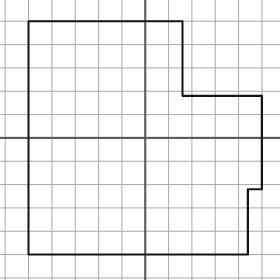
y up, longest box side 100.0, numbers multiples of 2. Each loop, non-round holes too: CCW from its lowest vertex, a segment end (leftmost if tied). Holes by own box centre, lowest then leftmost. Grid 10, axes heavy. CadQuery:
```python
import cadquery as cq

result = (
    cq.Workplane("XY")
    .moveTo(-50.0, -50.0)
    .lineTo(44.0, -50.0)
    .lineTo(44.0, -22.0)
    .lineTo(50.0, -22.0)
    .lineTo(50.0, 18.0)
    .lineTo(16.0, 18.0)
    .lineTo(16.0, 50.0)
    .lineTo(-50.0, 50.0)
    .close()
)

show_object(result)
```